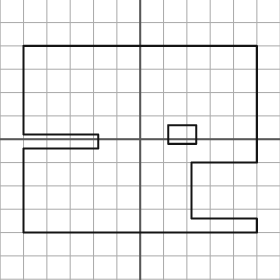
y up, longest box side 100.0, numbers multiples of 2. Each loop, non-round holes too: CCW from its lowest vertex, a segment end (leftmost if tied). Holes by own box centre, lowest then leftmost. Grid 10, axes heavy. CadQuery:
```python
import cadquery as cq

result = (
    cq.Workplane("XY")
    .moveTo(-50.0, -40.0)
    .lineTo(50.0, -40.0)
    .lineTo(50.0, -34.0)
    .lineTo(22.0, -34.0)
    .lineTo(22.0, -10.0)
    .lineTo(50.0, -10.0)
    .lineTo(50.0, 40.0)
    .lineTo(-50.0, 40.0)
    .lineTo(-50.0, 2.0)
    .lineTo(-18.0, 2.0)
    .lineTo(-18.0, -4.0)
    .lineTo(-50.0, -4.0)
    .close()
    .moveTo(12.0, -2.0)
    .lineTo(24.0, -2.0)
    .lineTo(24.0, 6.0)
    .lineTo(12.0, 6.0)
    .close()
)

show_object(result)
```